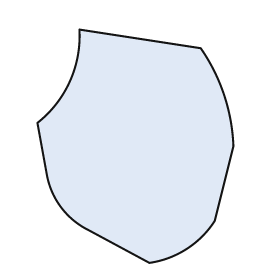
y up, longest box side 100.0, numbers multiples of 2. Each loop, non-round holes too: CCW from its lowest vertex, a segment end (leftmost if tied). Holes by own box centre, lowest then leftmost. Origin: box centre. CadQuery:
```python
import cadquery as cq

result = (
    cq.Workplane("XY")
    .moveTo(6.0, -50.0)
    .threePointArc((22.0, -44.0), (34.0, -32.0))
    .lineTo(42.0, 0.0)
    .threePointArc((38.0, 22.0), (28.0, 42.0))
    .lineTo(-24.0, 50.0)
    .threePointArc((-28.0, 28.0), (-42.0, 10.0))
    .lineTo(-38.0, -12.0)
    .threePointArc((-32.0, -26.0), (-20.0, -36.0))
    .close()
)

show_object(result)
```